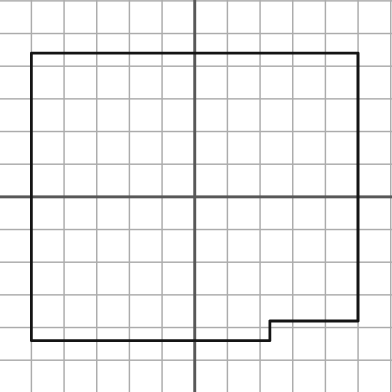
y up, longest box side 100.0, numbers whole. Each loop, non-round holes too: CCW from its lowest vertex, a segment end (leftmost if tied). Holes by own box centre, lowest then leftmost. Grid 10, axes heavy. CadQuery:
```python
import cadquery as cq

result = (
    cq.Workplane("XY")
    .moveTo(-50.0, -44.0)
    .lineTo(23.0, -44.0)
    .lineTo(23.0, -38.0)
    .lineTo(50.0, -38.0)
    .lineTo(50.0, 44.0)
    .lineTo(-50.0, 44.0)
    .close()
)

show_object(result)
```